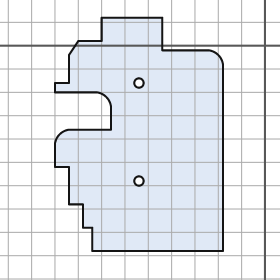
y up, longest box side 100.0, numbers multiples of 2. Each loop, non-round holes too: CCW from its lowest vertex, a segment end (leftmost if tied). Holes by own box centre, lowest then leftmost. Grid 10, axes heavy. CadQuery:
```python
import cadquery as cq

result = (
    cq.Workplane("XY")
    .moveTo(-74.0, -88.0)
    .lineTo(-18.0, -88.0)
    .lineTo(-18.0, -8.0)
    .threePointArc((-20.0, -4.0), (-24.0, -2.0))
    .lineTo(-44.0, -2.0)
    .lineTo(-44.0, 12.0)
    .lineTo(-70.0, 12.0)
    .lineTo(-70.0, 2.0)
    .lineTo(-80.0, 2.0)
    .lineTo(-84.0, -4.0)
    .lineTo(-84.0, -16.0)
    .lineTo(-90.0, -16.0)
    .lineTo(-90.0, -20.0)
    .lineTo(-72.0, -20.0)
    .threePointArc((-68.0, -22.0), (-66.0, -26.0))
    .lineTo(-66.0, -36.0)
    .lineTo(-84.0, -36.0)
    .threePointArc((-88.0, -38.0), (-90.0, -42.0))
    .lineTo(-90.0, -52.0)
    .lineTo(-84.0, -52.0)
    .lineTo(-84.0, -68.0)
    .lineTo(-78.0, -68.0)
    .lineTo(-78.0, -78.0)
    .lineTo(-74.0, -78.0)
    .close()
    .moveTo(-54.0, -58.0)
    .circle(2.0)
    .moveTo(-54.0, -16.0)
    .circle(2.0)
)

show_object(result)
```